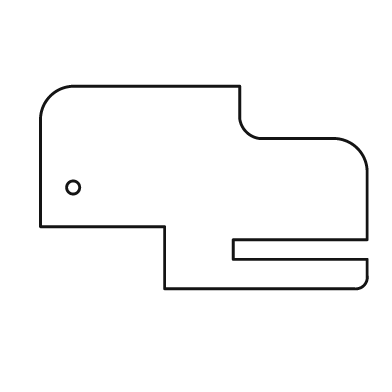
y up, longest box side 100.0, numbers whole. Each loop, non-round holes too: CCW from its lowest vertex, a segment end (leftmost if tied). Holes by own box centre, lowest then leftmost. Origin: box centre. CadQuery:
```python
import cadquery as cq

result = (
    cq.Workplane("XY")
    .moveTo(-12.0, -31.0)
    .lineTo(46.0, -31.0)
    .threePointArc((49.0, -30.0), (50.0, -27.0))
    .lineTo(50.0, -22.0)
    .lineTo(9.0, -22.0)
    .lineTo(9.0, -16.0)
    .lineTo(50.0, -16.0)
    .lineTo(50.0, 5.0)
    .threePointArc((47.0, 12.0), (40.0, 15.0))
    .lineTo(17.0, 15.0)
    .threePointArc((13.0, 17.0), (11.0, 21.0))
    .lineTo(11.0, 31.0)
    .lineTo(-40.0, 31.0)
    .threePointArc((-47.0, 28.0), (-50.0, 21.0))
    .lineTo(-50.0, -12.0)
    .lineTo(-12.0, -12.0)
    .close()
    .moveTo(-40.0, 0.0)
    .circle(2.0)
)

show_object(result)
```